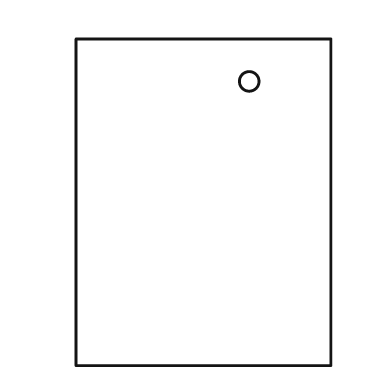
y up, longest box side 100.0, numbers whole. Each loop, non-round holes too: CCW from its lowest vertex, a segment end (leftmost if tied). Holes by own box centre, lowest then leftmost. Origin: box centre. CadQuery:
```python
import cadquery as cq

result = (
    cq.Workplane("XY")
    .moveTo(-39.0, -50.0)
    .lineTo(39.0, -50.0)
    .lineTo(39.0, 50.0)
    .lineTo(-39.0, 50.0)
    .close()
    .moveTo(14.0, 37.0)
    .circle(3.0)
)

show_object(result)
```